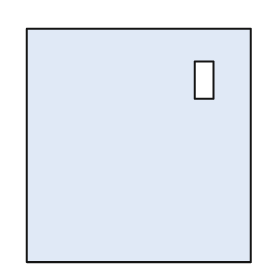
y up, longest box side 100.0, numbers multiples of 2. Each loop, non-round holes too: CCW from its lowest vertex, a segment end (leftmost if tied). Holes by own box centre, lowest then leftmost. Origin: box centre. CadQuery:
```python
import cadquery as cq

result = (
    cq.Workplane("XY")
    .moveTo(-48.0, -50.0)
    .lineTo(48.0, -50.0)
    .lineTo(48.0, 50.0)
    .lineTo(-48.0, 50.0)
    .close()
    .moveTo(24.0, 20.0)
    .lineTo(32.0, 20.0)
    .lineTo(32.0, 36.0)
    .lineTo(24.0, 36.0)
    .close()
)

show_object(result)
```